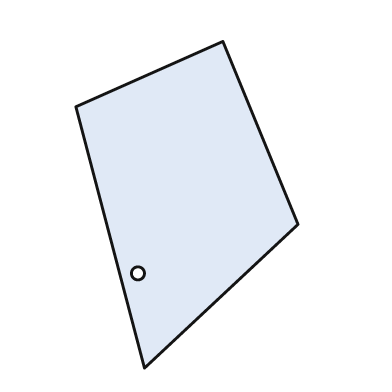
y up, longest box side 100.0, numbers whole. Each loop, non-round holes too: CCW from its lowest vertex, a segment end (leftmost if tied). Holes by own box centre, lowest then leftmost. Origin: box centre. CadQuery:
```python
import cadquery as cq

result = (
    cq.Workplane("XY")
    .moveTo(-13.0, -50.0)
    .lineTo(34.0, -6.0)
    .lineTo(11.0, 50.0)
    .lineTo(-34.0, 30.0)
    .close()
    .moveTo(-15.0, -21.0)
    .circle(2.0)
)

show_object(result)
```